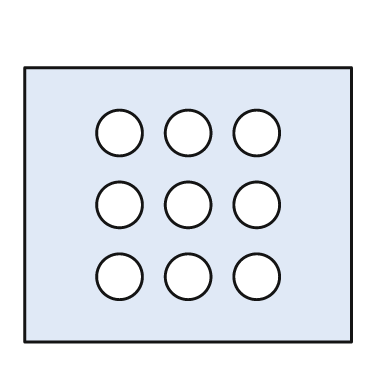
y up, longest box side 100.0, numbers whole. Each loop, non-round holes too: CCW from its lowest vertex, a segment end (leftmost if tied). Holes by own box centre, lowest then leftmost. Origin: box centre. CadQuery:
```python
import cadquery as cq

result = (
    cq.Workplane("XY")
    .moveTo(-50.0, -42.0)
    .lineTo(50.0, -42.0)
    .lineTo(50.0, 42.0)
    .lineTo(-50.0, 42.0)
    .close()
    .moveTo(-21.0, -22.0)
    .circle(7.0)
    .moveTo(0.0, -22.0)
    .circle(7.0)
    .moveTo(21.0, -22.0)
    .circle(7.0)
    .moveTo(-21.0, 0.0)
    .circle(7.0)
    .moveTo(0.0, 0.0)
    .circle(7.0)
    .moveTo(21.0, 0.0)
    .circle(7.0)
    .moveTo(-21.0, 22.0)
    .circle(7.0)
    .moveTo(0.0, 22.0)
    .circle(7.0)
    .moveTo(21.0, 22.0)
    .circle(7.0)
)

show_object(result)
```